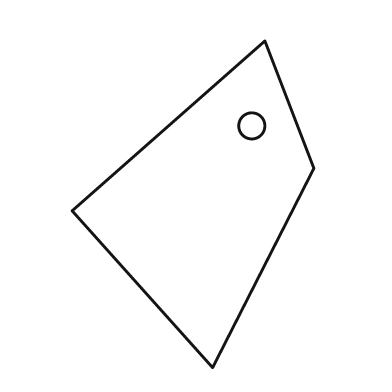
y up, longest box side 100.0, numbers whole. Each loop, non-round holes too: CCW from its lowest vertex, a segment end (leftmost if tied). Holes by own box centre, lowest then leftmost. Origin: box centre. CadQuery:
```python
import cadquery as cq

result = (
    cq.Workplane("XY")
    .moveTo(6.0, -50.0)
    .lineTo(37.0, 11.0)
    .lineTo(22.0, 50.0)
    .lineTo(-37.0, -2.0)
    .close()
    .moveTo(18.0, 24.0)
    .circle(4.0)
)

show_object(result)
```